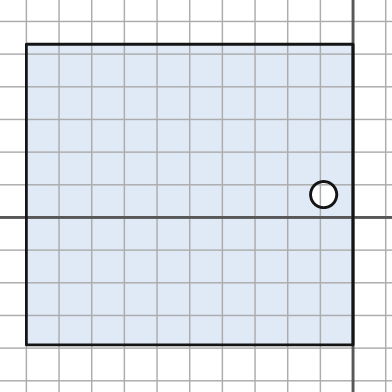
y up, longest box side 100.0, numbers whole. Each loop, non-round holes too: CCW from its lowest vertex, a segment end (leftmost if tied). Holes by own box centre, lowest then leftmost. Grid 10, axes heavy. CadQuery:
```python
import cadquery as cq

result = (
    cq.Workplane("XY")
    .moveTo(-100.0, -39.0)
    .lineTo(0.0, -39.0)
    .lineTo(0.0, 53.0)
    .lineTo(-100.0, 53.0)
    .close()
    .moveTo(-9.0, 7.0)
    .circle(4.0)
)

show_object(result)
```